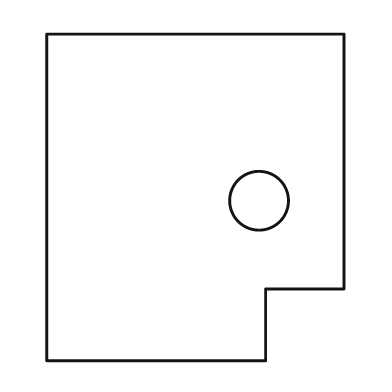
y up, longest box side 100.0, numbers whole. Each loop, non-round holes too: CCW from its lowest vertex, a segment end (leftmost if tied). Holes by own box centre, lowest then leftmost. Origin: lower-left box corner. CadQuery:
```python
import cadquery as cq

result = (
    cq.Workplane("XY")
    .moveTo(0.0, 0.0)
    .lineTo(67.0, 0.0)
    .lineTo(67.0, 22.0)
    .lineTo(91.0, 22.0)
    .lineTo(91.0, 100.0)
    .lineTo(0.0, 100.0)
    .close()
    .moveTo(65.0, 49.0)
    .circle(9.0)
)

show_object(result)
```